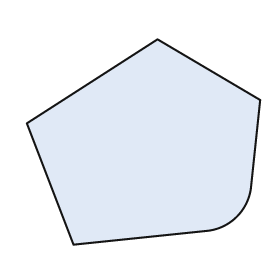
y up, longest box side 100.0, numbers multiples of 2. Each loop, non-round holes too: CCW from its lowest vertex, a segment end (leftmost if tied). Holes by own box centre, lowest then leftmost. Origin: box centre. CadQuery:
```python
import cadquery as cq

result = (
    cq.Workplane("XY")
    .moveTo(-30.0, -44.0)
    .lineTo(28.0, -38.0)
    .threePointArc((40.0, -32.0), (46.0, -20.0))
    .lineTo(50.0, 18.0)
    .lineTo(6.0, 44.0)
    .lineTo(-50.0, 8.0)
    .close()
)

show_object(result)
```